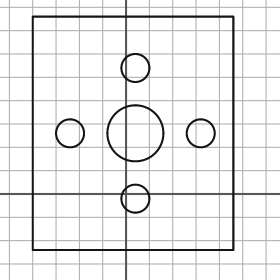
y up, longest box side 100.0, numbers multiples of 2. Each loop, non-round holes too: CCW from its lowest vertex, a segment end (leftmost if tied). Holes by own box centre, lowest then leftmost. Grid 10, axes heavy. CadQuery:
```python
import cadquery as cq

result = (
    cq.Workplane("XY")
    .moveTo(-40.0, -24.0)
    .lineTo(46.0, -24.0)
    .lineTo(46.0, 76.0)
    .lineTo(-40.0, 76.0)
    .close()
    .moveTo(4.0, -2.0)
    .circle(6.0)
    .moveTo(-24.0, 26.0)
    .circle(6.0)
    .moveTo(4.0, 26.0)
    .circle(12.0)
    .moveTo(32.0, 26.0)
    .circle(6.0)
    .moveTo(4.0, 54.0)
    .circle(6.0)
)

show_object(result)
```